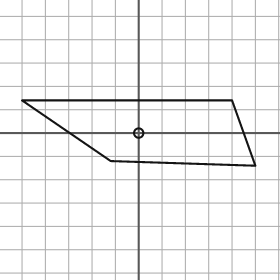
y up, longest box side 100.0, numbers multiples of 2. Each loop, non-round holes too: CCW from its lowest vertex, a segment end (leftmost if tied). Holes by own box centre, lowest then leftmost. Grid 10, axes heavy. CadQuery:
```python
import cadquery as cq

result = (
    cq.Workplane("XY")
    .moveTo(50.0, -14.0)
    .lineTo(40.0, 14.0)
    .lineTo(-50.0, 14.0)
    .lineTo(-12.0, -12.0)
    .close()
    .moveTo(0.0, 0.0)
    .circle(2.0)
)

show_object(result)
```